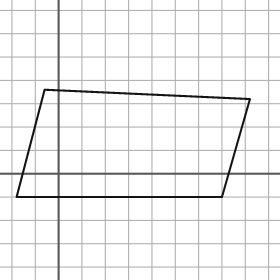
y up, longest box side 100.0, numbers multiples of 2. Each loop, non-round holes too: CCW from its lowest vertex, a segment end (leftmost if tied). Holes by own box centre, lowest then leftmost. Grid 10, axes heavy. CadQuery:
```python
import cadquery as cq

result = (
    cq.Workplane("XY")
    .moveTo(-18.0, -10.0)
    .lineTo(70.0, -10.0)
    .lineTo(82.0, 32.0)
    .lineTo(-6.0, 36.0)
    .close()
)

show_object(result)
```